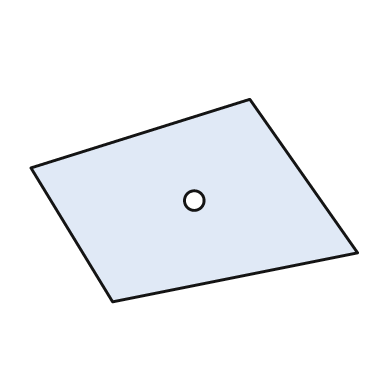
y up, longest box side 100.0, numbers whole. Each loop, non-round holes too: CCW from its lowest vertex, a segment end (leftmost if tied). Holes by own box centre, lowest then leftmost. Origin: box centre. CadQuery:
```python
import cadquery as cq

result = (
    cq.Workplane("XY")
    .moveTo(-25.0, -31.0)
    .lineTo(50.0, -16.0)
    .lineTo(17.0, 31.0)
    .lineTo(-50.0, 10.0)
    .close()
    .moveTo(0.0, 0.0)
    .circle(3.0)
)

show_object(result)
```